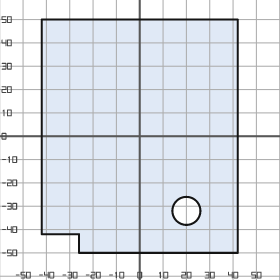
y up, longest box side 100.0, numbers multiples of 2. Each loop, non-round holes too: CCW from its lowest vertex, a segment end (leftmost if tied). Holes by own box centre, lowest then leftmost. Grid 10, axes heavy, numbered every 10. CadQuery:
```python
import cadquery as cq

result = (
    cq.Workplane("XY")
    .moveTo(-26.0, -50.0)
    .lineTo(42.0, -50.0)
    .lineTo(42.0, 50.0)
    .lineTo(-42.0, 50.0)
    .lineTo(-42.0, -42.0)
    .lineTo(-26.0, -42.0)
    .close()
    .moveTo(20.0, -32.0)
    .circle(6.0)
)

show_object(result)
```